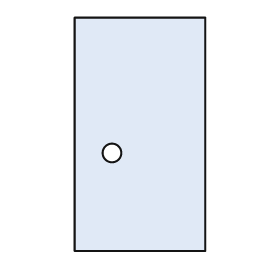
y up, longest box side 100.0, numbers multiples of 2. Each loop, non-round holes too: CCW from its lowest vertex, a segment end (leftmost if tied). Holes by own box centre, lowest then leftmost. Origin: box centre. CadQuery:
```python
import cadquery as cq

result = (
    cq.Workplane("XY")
    .moveTo(-28.0, -50.0)
    .lineTo(28.0, -50.0)
    .lineTo(28.0, 50.0)
    .lineTo(-28.0, 50.0)
    .close()
    .moveTo(-12.0, -8.0)
    .circle(4.0)
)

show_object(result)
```